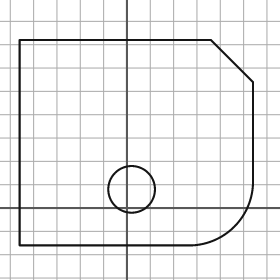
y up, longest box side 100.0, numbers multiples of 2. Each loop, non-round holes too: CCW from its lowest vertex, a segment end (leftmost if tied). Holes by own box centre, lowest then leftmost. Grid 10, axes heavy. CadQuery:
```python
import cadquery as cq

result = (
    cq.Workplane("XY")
    .moveTo(-46.0, -16.0)
    .lineTo(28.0, -16.0)
    .threePointArc((46.0, -8.0), (54.0, 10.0))
    .lineTo(54.0, 54.0)
    .lineTo(36.0, 72.0)
    .lineTo(-46.0, 72.0)
    .close()
    .moveTo(2.0, 8.0)
    .circle(10.0)
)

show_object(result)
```